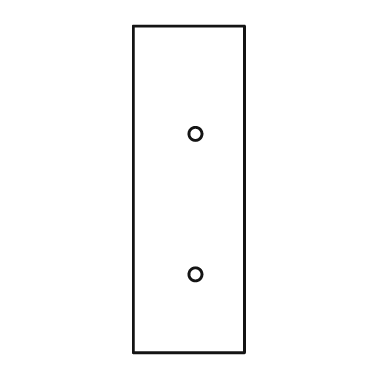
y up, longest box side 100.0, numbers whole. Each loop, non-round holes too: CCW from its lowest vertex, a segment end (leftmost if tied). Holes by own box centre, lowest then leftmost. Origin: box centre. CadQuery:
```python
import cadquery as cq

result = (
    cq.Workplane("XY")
    .moveTo(-17.0, -50.0)
    .lineTo(17.0, -50.0)
    .lineTo(17.0, 50.0)
    .lineTo(-17.0, 50.0)
    .close()
    .moveTo(2.0, -26.0)
    .circle(2.0)
    .moveTo(2.0, 17.0)
    .circle(2.0)
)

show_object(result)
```